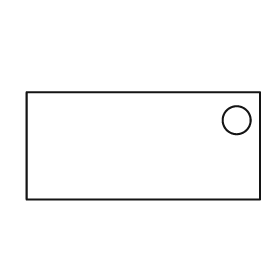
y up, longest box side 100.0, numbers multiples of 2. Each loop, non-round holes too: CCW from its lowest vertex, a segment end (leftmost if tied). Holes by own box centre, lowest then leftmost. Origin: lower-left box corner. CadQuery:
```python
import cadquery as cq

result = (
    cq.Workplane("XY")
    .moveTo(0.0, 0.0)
    .lineTo(100.0, 0.0)
    .lineTo(100.0, 46.0)
    .lineTo(0.0, 46.0)
    .close()
    .moveTo(90.0, 34.0)
    .circle(6.0)
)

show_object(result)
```